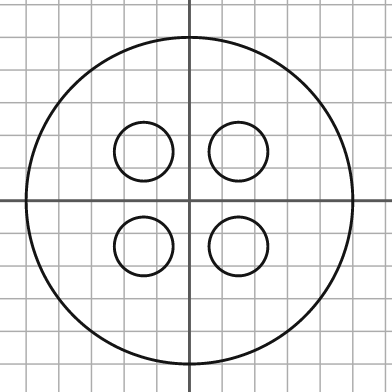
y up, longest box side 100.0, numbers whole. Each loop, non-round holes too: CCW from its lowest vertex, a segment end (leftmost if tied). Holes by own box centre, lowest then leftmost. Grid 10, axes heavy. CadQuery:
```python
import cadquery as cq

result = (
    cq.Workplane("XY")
    .moveTo(0.0, 0.0)
    .circle(50.0)
    .moveTo(-14.0, -14.0)
    .circle(9.0)
    .moveTo(15.0, -14.0)
    .circle(9.0)
    .moveTo(-14.0, 15.0)
    .circle(9.0)
    .moveTo(15.0, 15.0)
    .circle(9.0)
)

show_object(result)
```